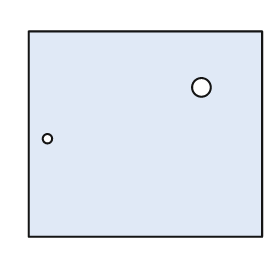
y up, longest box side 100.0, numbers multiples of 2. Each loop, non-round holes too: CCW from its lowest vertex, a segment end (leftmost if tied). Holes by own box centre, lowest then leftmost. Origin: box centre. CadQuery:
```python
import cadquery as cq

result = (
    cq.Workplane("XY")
    .moveTo(-50.0, -44.0)
    .lineTo(50.0, -44.0)
    .lineTo(50.0, 44.0)
    .lineTo(-50.0, 44.0)
    .close()
    .moveTo(-42.0, -2.0)
    .circle(2.0)
    .moveTo(24.0, 20.0)
    .circle(4.0)
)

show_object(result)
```